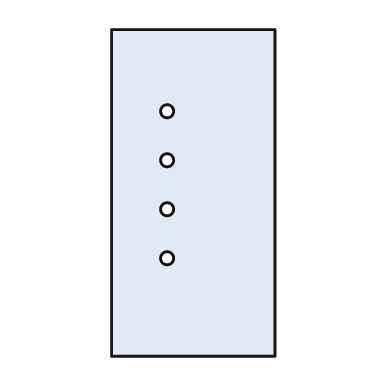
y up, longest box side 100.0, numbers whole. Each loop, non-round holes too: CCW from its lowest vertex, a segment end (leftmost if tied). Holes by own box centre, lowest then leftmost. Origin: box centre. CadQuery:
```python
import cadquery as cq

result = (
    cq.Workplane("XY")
    .moveTo(-25.0, -50.0)
    .lineTo(25.0, -50.0)
    .lineTo(25.0, 50.0)
    .lineTo(-25.0, 50.0)
    .close()
    .moveTo(-8.0, -20.0)
    .circle(2.0)
    .moveTo(-8.0, -5.0)
    .circle(2.0)
    .moveTo(-8.0, 10.0)
    .circle(2.0)
    .moveTo(-8.0, 25.0)
    .circle(2.0)
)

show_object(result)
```